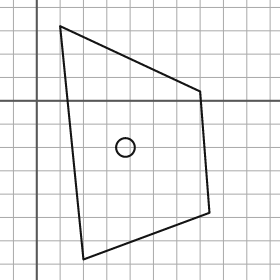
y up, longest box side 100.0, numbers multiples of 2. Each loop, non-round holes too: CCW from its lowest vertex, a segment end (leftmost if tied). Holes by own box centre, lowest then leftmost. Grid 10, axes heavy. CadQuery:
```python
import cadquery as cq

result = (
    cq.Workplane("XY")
    .moveTo(20.0, -68.0)
    .lineTo(74.0, -48.0)
    .lineTo(70.0, 4.0)
    .lineTo(10.0, 32.0)
    .close()
    .moveTo(38.0, -20.0)
    .circle(4.0)
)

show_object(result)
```